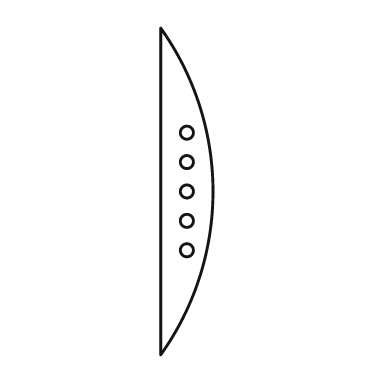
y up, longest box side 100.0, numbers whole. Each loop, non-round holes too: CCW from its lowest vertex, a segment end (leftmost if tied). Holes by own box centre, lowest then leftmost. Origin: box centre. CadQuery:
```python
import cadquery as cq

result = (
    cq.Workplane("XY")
    .moveTo(-8.0, -50.0)
    .threePointArc((8.0, 0.0), (-8.0, 50.0))
    .close()
    .moveTo(0.0, -18.0)
    .circle(2.0)
    .moveTo(0.0, -9.0)
    .circle(2.0)
    .moveTo(0.0, 0.0)
    .circle(2.0)
    .moveTo(0.0, 9.0)
    .circle(2.0)
    .moveTo(0.0, 18.0)
    .circle(2.0)
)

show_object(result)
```